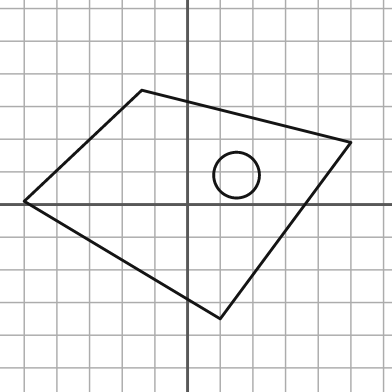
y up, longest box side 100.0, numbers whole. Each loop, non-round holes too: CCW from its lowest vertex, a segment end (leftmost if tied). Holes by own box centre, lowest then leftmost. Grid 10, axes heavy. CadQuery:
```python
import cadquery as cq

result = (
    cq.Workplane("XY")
    .moveTo(10.0, -35.0)
    .lineTo(50.0, 19.0)
    .lineTo(-14.0, 35.0)
    .lineTo(-50.0, 1.0)
    .close()
    .moveTo(15.0, 9.0)
    .circle(7.0)
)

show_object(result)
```